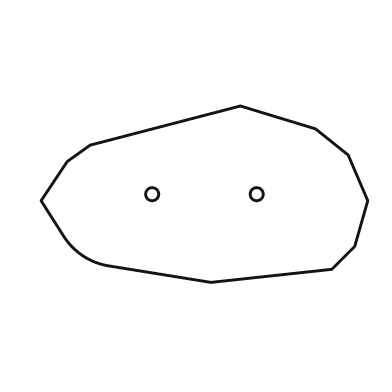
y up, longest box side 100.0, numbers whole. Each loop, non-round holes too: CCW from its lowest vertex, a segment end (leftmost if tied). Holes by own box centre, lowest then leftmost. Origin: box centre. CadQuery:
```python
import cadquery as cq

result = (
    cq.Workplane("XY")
    .moveTo(2.0, -27.0)
    .lineTo(39.0, -23.0)
    .lineTo(46.0, -16.0)
    .lineTo(50.0, -2.0)
    .lineTo(44.0, 12.0)
    .lineTo(34.0, 20.0)
    .lineTo(11.0, 27.0)
    .lineTo(-35.0, 15.0)
    .lineTo(-42.0, 10.0)
    .lineTo(-50.0, -2.0)
    .lineTo(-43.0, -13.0)
    .threePointArc((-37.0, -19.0), (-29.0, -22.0))
    .close()
    .moveTo(-16.0, 0.0)
    .circle(2.0)
    .moveTo(16.0, 0.0)
    .circle(2.0)
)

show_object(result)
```